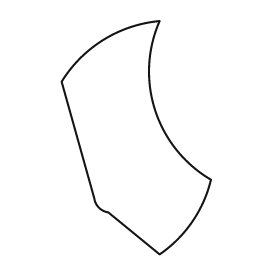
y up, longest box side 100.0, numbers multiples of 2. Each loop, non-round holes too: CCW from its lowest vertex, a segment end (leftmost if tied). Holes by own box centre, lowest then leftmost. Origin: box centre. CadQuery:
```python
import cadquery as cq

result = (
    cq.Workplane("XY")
    .moveTo(10.0, -50.0)
    .threePointArc((24.0, -36.0), (32.0, -18.0))
    .threePointArc((8.0, 12.0), (10.0, 50.0))
    .threePointArc((-14.0, 42.0), (-32.0, 24.0))
    .lineTo(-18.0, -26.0)
    .threePointArc((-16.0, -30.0), (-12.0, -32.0))
    .close()
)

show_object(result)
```